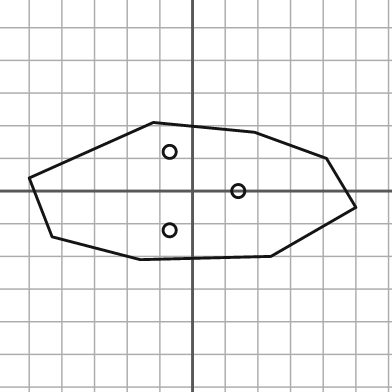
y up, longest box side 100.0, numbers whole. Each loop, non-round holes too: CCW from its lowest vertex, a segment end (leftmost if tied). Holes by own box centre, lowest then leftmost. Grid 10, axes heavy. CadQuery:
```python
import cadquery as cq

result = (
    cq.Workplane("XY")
    .moveTo(-16.0, -21.0)
    .lineTo(24.0, -20.0)
    .lineTo(50.0, -5.0)
    .lineTo(41.0, 10.0)
    .lineTo(19.0, 18.0)
    .lineTo(-12.0, 21.0)
    .lineTo(-50.0, 4.0)
    .lineTo(-43.0, -14.0)
    .close()
    .moveTo(-7.0, -12.0)
    .circle(2.0)
    .moveTo(14.0, 0.0)
    .circle(2.0)
    .moveTo(-7.0, 12.0)
    .circle(2.0)
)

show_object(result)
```